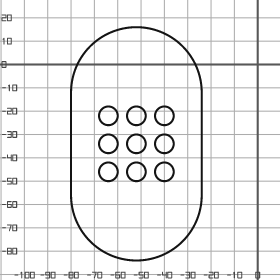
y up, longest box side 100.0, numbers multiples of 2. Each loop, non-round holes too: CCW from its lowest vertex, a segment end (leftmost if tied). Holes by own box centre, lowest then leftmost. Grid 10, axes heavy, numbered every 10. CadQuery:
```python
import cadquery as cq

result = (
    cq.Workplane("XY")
    .moveTo(-80.0, -56.0)
    .threePointArc((-52.0, -84.0), (-24.0, -56.0))
    .lineTo(-24.0, -12.0)
    .threePointArc((-52.0, 16.0), (-80.0, -12.0))
    .close()
    .moveTo(-64.0, -46.0)
    .circle(4.0)
    .moveTo(-52.0, -46.0)
    .circle(4.0)
    .moveTo(-40.0, -46.0)
    .circle(4.0)
    .moveTo(-64.0, -34.0)
    .circle(4.0)
    .moveTo(-52.0, -34.0)
    .circle(4.0)
    .moveTo(-40.0, -34.0)
    .circle(4.0)
    .moveTo(-64.0, -22.0)
    .circle(4.0)
    .moveTo(-52.0, -22.0)
    .circle(4.0)
    .moveTo(-40.0, -22.0)
    .circle(4.0)
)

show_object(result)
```